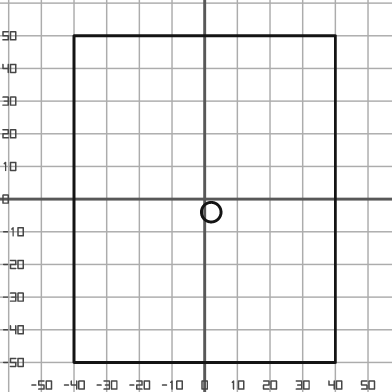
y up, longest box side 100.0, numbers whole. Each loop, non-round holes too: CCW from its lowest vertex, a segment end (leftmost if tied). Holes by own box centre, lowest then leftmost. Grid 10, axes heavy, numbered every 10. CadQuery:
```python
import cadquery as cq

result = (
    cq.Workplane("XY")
    .moveTo(-40.0, -50.0)
    .lineTo(40.0, -50.0)
    .lineTo(40.0, 50.0)
    .lineTo(-40.0, 50.0)
    .close()
    .moveTo(2.0, -4.0)
    .circle(3.0)
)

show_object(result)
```